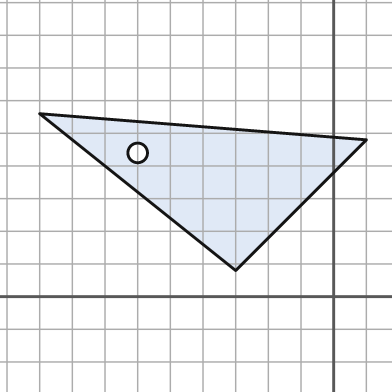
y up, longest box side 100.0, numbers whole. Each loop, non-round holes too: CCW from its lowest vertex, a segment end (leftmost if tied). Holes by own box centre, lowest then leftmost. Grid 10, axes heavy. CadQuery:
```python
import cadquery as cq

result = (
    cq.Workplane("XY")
    .moveTo(-30.0, 8.0)
    .lineTo(10.0, 48.0)
    .lineTo(-90.0, 56.0)
    .close()
    .moveTo(-60.0, 44.0)
    .circle(3.0)
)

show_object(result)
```